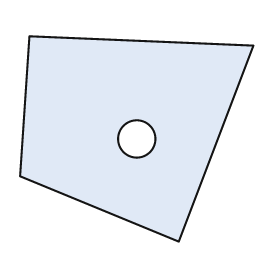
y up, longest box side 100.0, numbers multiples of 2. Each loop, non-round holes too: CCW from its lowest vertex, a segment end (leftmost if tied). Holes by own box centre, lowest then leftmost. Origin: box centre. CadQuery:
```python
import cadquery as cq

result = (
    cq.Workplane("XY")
    .moveTo(18.0, -44.0)
    .lineTo(50.0, 40.0)
    .lineTo(-46.0, 44.0)
    .lineTo(-50.0, -16.0)
    .close()
    .moveTo(0.0, 0.0)
    .circle(8.0)
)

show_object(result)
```